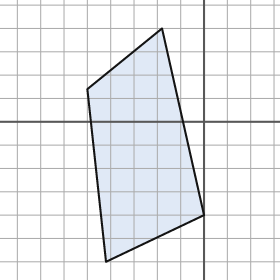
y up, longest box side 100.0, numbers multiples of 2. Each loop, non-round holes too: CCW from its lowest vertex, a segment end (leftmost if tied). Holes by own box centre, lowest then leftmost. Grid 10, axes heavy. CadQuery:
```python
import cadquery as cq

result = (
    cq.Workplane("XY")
    .moveTo(-42.0, -60.0)
    .lineTo(0.0, -40.0)
    .lineTo(-18.0, 40.0)
    .lineTo(-50.0, 14.0)
    .close()
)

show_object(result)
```